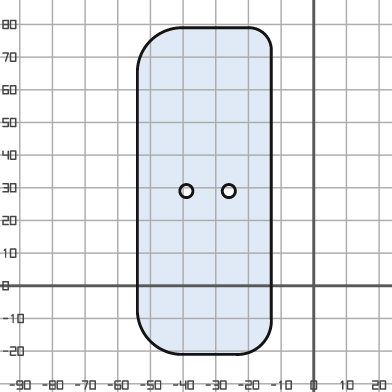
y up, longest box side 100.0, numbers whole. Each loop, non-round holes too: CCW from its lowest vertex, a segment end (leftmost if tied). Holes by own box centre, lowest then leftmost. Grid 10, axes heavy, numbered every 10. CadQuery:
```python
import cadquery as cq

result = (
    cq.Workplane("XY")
    .moveTo(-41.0, -21.0)
    .lineTo(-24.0, -21.0)
    .threePointArc((-16.0, -18.0), (-13.0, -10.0))
    .lineTo(-13.0, 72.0)
    .threePointArc((-15.0, 77.0), (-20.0, 79.0))
    .lineTo(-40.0, 79.0)
    .threePointArc((-50.0, 75.0), (-54.0, 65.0))
    .lineTo(-54.0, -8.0)
    .threePointArc((-50.0, -17.0), (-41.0, -21.0))
    .close()
    .moveTo(-39.0, 29.0)
    .circle(2.0)
    .moveTo(-26.0, 29.0)
    .circle(2.0)
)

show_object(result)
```